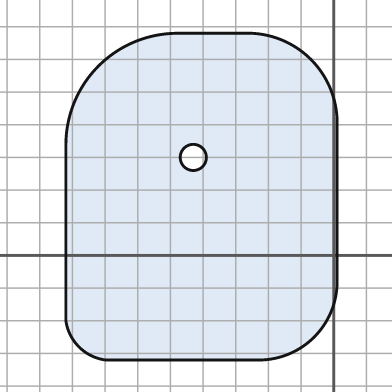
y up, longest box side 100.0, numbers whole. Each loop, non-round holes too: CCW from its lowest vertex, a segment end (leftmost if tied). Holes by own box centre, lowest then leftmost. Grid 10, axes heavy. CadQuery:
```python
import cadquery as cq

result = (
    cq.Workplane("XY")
    .moveTo(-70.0, -32.0)
    .lineTo(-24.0, -32.0)
    .threePointArc((-6.0, -25.0), (1.0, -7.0))
    .lineTo(1.0, 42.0)
    .threePointArc((-7.0, 60.0), (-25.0, 68.0))
    .lineTo(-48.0, 68.0)
    .threePointArc((-72.0, 58.0), (-82.0, 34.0))
    .lineTo(-82.0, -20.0)
    .threePointArc((-78.0, -28.0), (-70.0, -32.0))
    .close()
    .moveTo(-43.0, 30.0)
    .circle(4.0)
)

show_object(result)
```